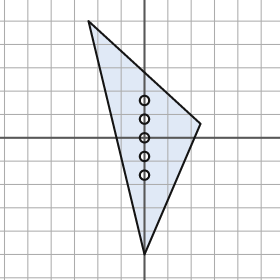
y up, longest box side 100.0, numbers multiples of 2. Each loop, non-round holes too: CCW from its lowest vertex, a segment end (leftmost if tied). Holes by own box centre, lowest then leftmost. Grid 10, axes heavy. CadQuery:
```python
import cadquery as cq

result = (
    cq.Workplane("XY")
    .moveTo(0.0, -50.0)
    .lineTo(24.0, 6.0)
    .lineTo(-24.0, 50.0)
    .close()
    .moveTo(0.0, -16.0)
    .circle(2.0)
    .moveTo(0.0, -8.0)
    .circle(2.0)
    .moveTo(0.0, 0.0)
    .circle(2.0)
    .moveTo(0.0, 8.0)
    .circle(2.0)
    .moveTo(0.0, 16.0)
    .circle(2.0)
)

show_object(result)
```